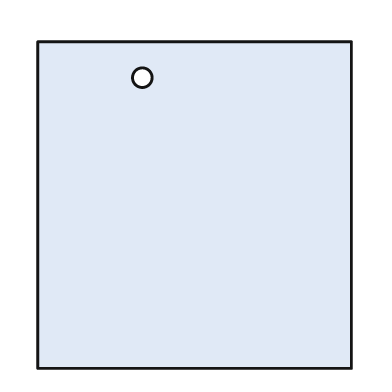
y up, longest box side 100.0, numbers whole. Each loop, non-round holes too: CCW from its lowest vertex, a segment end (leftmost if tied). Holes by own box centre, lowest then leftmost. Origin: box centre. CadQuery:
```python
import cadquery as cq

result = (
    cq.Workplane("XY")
    .moveTo(-48.0, -50.0)
    .lineTo(48.0, -50.0)
    .lineTo(48.0, 50.0)
    .lineTo(-48.0, 50.0)
    .close()
    .moveTo(-16.0, 39.0)
    .circle(3.0)
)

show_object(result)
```